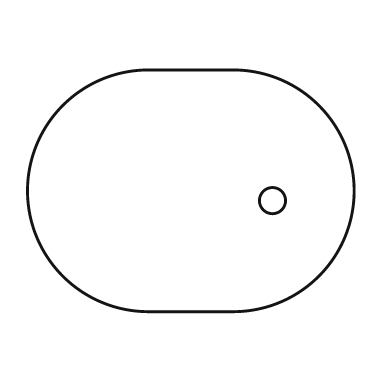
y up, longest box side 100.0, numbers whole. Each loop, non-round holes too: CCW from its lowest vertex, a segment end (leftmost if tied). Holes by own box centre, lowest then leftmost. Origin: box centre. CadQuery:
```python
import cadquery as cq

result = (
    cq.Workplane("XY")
    .moveTo(-13.0, -37.0)
    .lineTo(13.0, -37.0)
    .threePointArc((50.0, 0.0), (13.0, 37.0))
    .lineTo(-13.0, 37.0)
    .threePointArc((-50.0, 0.0), (-13.0, -37.0))
    .close()
    .moveTo(25.0, -3.0)
    .circle(4.0)
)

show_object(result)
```